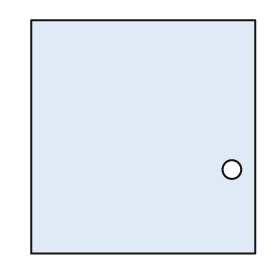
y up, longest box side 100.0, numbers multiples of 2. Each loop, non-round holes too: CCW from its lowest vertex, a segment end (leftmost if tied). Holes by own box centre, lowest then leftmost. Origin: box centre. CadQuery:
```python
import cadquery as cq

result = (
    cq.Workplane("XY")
    .moveTo(-48.0, -50.0)
    .lineTo(48.0, -50.0)
    .lineTo(48.0, 50.0)
    .lineTo(-48.0, 50.0)
    .close()
    .moveTo(38.0, -14.0)
    .circle(4.0)
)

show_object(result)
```